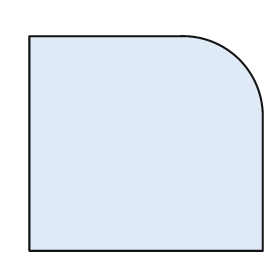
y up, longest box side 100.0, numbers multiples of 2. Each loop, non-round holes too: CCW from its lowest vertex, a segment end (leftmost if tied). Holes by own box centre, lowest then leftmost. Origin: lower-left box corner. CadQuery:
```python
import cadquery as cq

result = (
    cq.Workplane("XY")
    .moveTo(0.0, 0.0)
    .lineTo(100.0, 0.0)
    .lineTo(100.0, 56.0)
    .threePointArc((90.0, 82.0), (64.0, 92.0))
    .lineTo(0.0, 92.0)
    .close()
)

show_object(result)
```